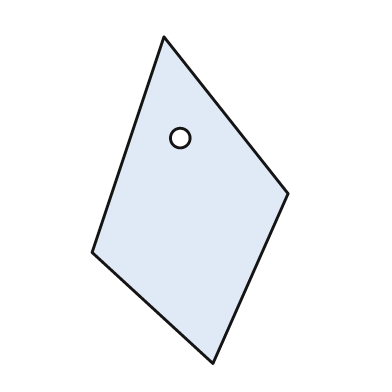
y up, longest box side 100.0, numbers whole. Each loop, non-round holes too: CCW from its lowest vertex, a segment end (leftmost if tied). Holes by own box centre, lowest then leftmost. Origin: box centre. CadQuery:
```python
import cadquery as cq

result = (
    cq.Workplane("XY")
    .moveTo(7.0, -50.0)
    .lineTo(30.0, 2.0)
    .lineTo(-8.0, 50.0)
    .lineTo(-30.0, -16.0)
    .close()
    .moveTo(-3.0, 19.0)
    .circle(3.0)
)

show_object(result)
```